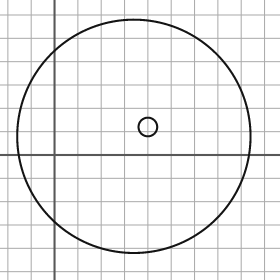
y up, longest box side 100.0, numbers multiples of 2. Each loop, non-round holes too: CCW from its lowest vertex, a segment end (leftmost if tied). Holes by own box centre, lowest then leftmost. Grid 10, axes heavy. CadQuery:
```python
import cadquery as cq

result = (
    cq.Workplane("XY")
    .moveTo(34.0, 8.0)
    .circle(50.0)
    .moveTo(40.0, 12.0)
    .circle(4.0)
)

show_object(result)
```